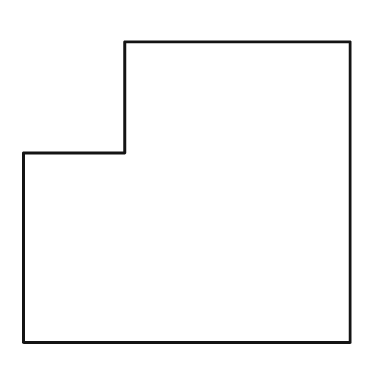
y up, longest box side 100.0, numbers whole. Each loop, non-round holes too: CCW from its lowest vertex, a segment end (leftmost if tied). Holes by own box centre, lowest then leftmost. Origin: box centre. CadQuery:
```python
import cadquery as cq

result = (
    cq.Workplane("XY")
    .moveTo(-50.0, -46.0)
    .lineTo(50.0, -46.0)
    .lineTo(50.0, 46.0)
    .lineTo(-19.0, 46.0)
    .lineTo(-19.0, 12.0)
    .lineTo(-50.0, 12.0)
    .close()
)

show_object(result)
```